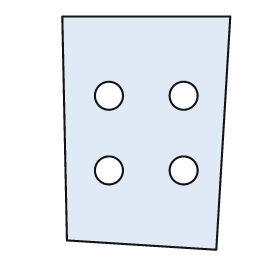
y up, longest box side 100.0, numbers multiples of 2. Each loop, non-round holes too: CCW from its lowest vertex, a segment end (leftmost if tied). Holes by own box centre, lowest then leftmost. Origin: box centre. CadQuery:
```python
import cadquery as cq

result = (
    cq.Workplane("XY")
    .moveTo(30.0, -50.0)
    .lineTo(36.0, 50.0)
    .lineTo(-36.0, 50.0)
    .lineTo(-34.0, -46.0)
    .close()
    .moveTo(-16.0, -16.0)
    .circle(6.0)
    .moveTo(16.0, -16.0)
    .circle(6.0)
    .moveTo(-16.0, 16.0)
    .circle(6.0)
    .moveTo(16.0, 16.0)
    .circle(6.0)
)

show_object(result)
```